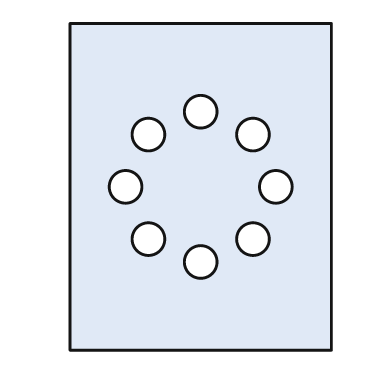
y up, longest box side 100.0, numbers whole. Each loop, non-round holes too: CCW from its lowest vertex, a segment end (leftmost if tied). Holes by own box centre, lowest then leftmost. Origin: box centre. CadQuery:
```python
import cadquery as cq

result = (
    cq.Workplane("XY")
    .moveTo(-40.0, -50.0)
    .lineTo(40.0, -50.0)
    .lineTo(40.0, 50.0)
    .lineTo(-40.0, 50.0)
    .close()
    .moveTo(0.0, -23.0)
    .circle(5.0)
    .moveTo(-16.0, -16.0)
    .circle(5.0)
    .moveTo(16.0, -16.0)
    .circle(5.0)
    .moveTo(-23.0, 0.0)
    .circle(5.0)
    .moveTo(23.0, 0.0)
    .circle(5.0)
    .moveTo(-16.0, 16.0)
    .circle(5.0)
    .moveTo(16.0, 16.0)
    .circle(5.0)
    .moveTo(0.0, 23.0)
    .circle(5.0)
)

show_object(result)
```